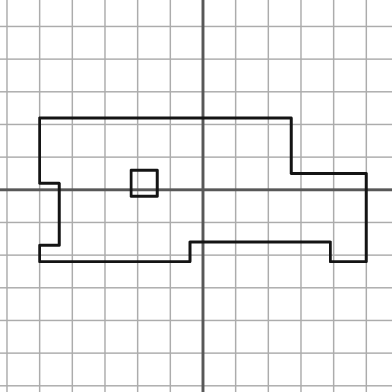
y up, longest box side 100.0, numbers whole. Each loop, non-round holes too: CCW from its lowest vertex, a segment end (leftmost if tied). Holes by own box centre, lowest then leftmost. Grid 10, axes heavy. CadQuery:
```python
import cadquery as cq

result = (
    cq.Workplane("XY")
    .moveTo(-50.0, -22.0)
    .lineTo(-4.0, -22.0)
    .lineTo(-4.0, -16.0)
    .lineTo(39.0, -16.0)
    .lineTo(39.0, -22.0)
    .lineTo(50.0, -22.0)
    .lineTo(50.0, 5.0)
    .lineTo(27.0, 5.0)
    .lineTo(27.0, 22.0)
    .lineTo(-50.0, 22.0)
    .lineTo(-50.0, 2.0)
    .lineTo(-44.0, 2.0)
    .lineTo(-44.0, -17.0)
    .lineTo(-50.0, -17.0)
    .close()
    .moveTo(-22.0, -2.0)
    .lineTo(-14.0, -2.0)
    .lineTo(-14.0, 6.0)
    .lineTo(-22.0, 6.0)
    .close()
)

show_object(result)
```